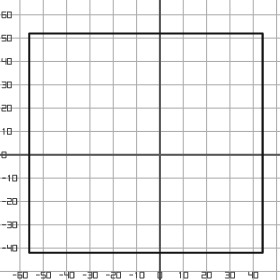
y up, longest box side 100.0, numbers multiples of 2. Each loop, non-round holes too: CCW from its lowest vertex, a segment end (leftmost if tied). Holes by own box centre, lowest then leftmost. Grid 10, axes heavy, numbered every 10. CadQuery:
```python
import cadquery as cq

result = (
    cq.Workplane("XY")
    .moveTo(-56.0, -42.0)
    .lineTo(44.0, -42.0)
    .lineTo(44.0, 52.0)
    .lineTo(-56.0, 52.0)
    .close()
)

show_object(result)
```